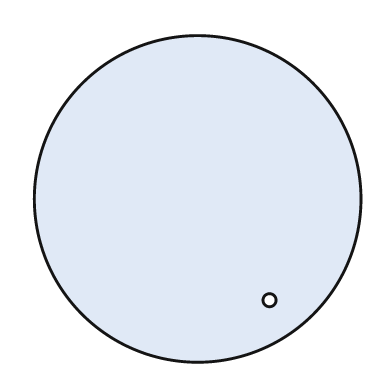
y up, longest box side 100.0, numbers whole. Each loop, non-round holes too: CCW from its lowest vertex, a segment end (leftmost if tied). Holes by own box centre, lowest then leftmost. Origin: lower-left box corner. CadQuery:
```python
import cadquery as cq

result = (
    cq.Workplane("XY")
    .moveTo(50.0, 50.0)
    .circle(50.0)
    .moveTo(72.0, 19.0)
    .circle(2.0)
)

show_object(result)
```